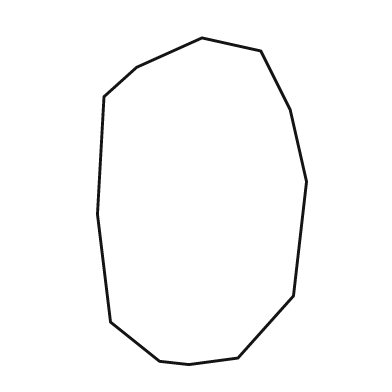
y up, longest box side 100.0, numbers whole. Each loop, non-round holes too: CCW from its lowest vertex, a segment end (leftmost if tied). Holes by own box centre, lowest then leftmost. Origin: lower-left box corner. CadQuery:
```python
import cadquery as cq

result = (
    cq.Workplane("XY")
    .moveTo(28.0, 0.0)
    .lineTo(43.0, 2.0)
    .lineTo(60.0, 21.0)
    .lineTo(64.0, 56.0)
    .lineTo(59.0, 78.0)
    .lineTo(50.0, 96.0)
    .lineTo(32.0, 100.0)
    .lineTo(12.0, 91.0)
    .lineTo(2.0, 82.0)
    .lineTo(0.0, 46.0)
    .lineTo(4.0, 13.0)
    .lineTo(19.0, 1.0)
    .close()
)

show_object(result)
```